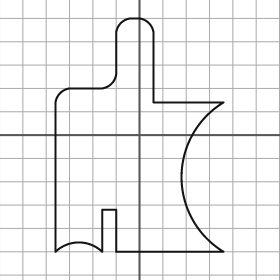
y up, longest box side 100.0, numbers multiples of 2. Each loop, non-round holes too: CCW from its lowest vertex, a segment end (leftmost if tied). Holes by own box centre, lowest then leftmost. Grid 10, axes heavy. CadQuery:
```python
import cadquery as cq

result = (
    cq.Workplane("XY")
    .moveTo(-36.0, -50.0)
    .threePointArc((-26.0, -46.0), (-16.0, -50.0))
    .lineTo(-16.0, -32.0)
    .lineTo(-10.0, -32.0)
    .lineTo(-10.0, -50.0)
    .lineTo(36.0, -50.0)
    .threePointArc((18.0, -18.0), (36.0, 14.0))
    .lineTo(6.0, 14.0)
    .lineTo(6.0, 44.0)
    .threePointArc((4.0, 48.0), (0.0, 50.0))
    .lineTo(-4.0, 50.0)
    .threePointArc((-8.0, 48.0), (-10.0, 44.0))
    .lineTo(-10.0, 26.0)
    .threePointArc((-12.0, 22.0), (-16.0, 20.0))
    .lineTo(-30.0, 20.0)
    .threePointArc((-34.0, 18.0), (-36.0, 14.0))
    .close()
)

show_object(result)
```